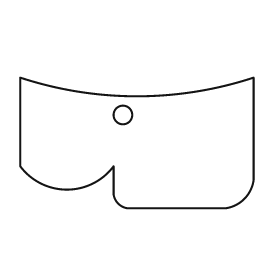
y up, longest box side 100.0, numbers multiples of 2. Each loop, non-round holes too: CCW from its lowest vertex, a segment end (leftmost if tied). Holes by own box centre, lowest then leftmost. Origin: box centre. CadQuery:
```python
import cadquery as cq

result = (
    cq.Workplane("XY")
    .moveTo(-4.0, -28.0)
    .lineTo(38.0, -28.0)
    .threePointArc((46.0, -24.0), (50.0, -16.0))
    .lineTo(50.0, 28.0)
    .threePointArc((0.0, 20.0), (-50.0, 28.0))
    .lineTo(-50.0, -10.0)
    .threePointArc((-30.0, -20.0), (-10.0, -10.0))
    .lineTo(-10.0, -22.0)
    .threePointArc((-8.0, -26.0), (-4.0, -28.0))
    .close()
    .moveTo(-6.0, 12.0)
    .circle(4.0)
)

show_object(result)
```